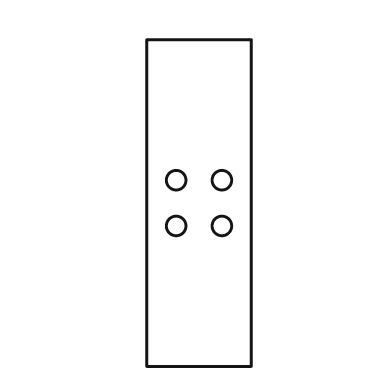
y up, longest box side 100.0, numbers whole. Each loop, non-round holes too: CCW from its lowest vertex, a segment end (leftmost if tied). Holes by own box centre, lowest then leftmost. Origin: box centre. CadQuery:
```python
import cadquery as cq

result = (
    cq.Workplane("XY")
    .moveTo(-16.0, -50.0)
    .lineTo(16.0, -50.0)
    .lineTo(16.0, 50.0)
    .lineTo(-16.0, 50.0)
    .close()
    .moveTo(-7.0, -7.0)
    .circle(3.0)
    .moveTo(7.0, -7.0)
    .circle(3.0)
    .moveTo(-7.0, 7.0)
    .circle(3.0)
    .moveTo(7.0, 7.0)
    .circle(3.0)
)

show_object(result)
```